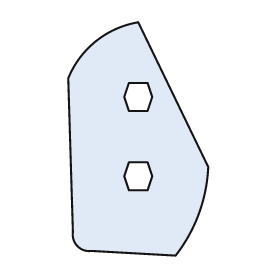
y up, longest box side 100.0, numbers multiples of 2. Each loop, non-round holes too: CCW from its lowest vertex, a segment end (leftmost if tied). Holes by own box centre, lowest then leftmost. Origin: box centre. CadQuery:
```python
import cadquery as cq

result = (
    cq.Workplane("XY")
    .moveTo(16.0, -50.0)
    .threePointArc((26.0, -32.0), (30.0, -12.0))
    .lineTo(0.0, 50.0)
    .threePointArc((-18.0, 42.0), (-30.0, 26.0))
    .lineTo(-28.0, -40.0)
    .threePointArc((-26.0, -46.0), (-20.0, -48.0))
    .close()
    .moveTo(-4.0, -22.0)
    .lineTo(4.0, -22.0)
    .lineTo(6.0, -16.0)
    .lineTo(4.0, -10.0)
    .lineTo(-4.0, -10.0)
    .lineTo(-6.0, -16.0)
    .close()
    .moveTo(-4.0, 12.0)
    .lineTo(4.0, 12.0)
    .lineTo(6.0, 18.0)
    .lineTo(4.0, 24.0)
    .lineTo(-4.0, 24.0)
    .lineTo(-6.0, 18.0)
    .close()
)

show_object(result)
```